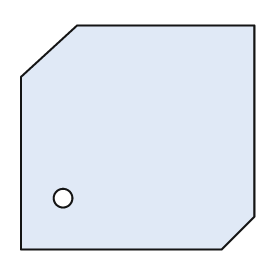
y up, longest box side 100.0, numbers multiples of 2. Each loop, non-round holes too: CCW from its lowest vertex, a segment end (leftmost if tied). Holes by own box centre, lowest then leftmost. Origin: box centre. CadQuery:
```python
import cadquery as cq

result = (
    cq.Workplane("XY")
    .moveTo(-50.0, -48.0)
    .lineTo(36.0, -48.0)
    .lineTo(50.0, -34.0)
    .lineTo(50.0, 48.0)
    .lineTo(-26.0, 48.0)
    .lineTo(-50.0, 26.0)
    .close()
    .moveTo(-32.0, -26.0)
    .circle(4.0)
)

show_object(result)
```